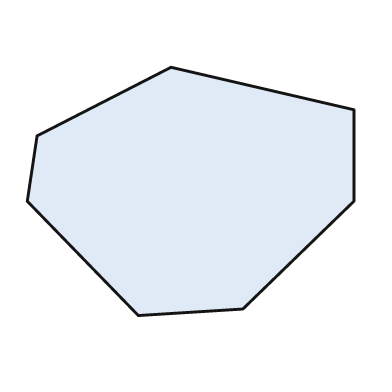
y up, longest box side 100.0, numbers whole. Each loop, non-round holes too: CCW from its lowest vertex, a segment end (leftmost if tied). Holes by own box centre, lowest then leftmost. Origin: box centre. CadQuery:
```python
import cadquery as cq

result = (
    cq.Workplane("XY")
    .moveTo(-16.0, -38.0)
    .lineTo(16.0, -36.0)
    .lineTo(50.0, -3.0)
    .lineTo(50.0, 25.0)
    .lineTo(-6.0, 38.0)
    .lineTo(-47.0, 17.0)
    .lineTo(-50.0, -3.0)
    .close()
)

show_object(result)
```